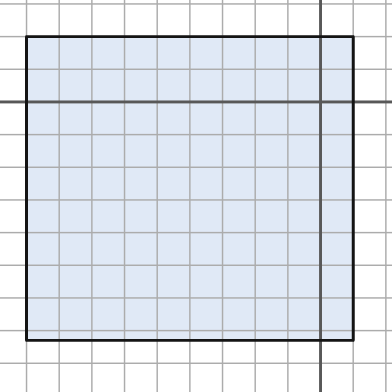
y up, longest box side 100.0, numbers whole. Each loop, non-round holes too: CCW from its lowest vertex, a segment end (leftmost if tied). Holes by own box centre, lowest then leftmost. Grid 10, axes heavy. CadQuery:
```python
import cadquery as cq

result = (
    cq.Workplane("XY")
    .moveTo(-90.0, -73.0)
    .lineTo(10.0, -73.0)
    .lineTo(10.0, 20.0)
    .lineTo(-90.0, 20.0)
    .close()
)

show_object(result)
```